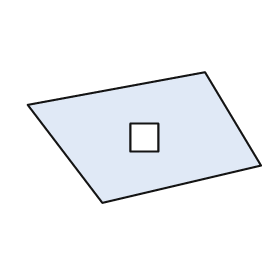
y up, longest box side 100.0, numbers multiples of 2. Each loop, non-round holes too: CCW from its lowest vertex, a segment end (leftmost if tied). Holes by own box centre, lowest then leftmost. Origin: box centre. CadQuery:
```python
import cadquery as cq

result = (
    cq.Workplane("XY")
    .moveTo(-18.0, -28.0)
    .lineTo(50.0, -12.0)
    .lineTo(26.0, 28.0)
    .lineTo(-50.0, 14.0)
    .close()
    .moveTo(-6.0, -6.0)
    .lineTo(6.0, -6.0)
    .lineTo(6.0, 6.0)
    .lineTo(-6.0, 6.0)
    .close()
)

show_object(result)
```